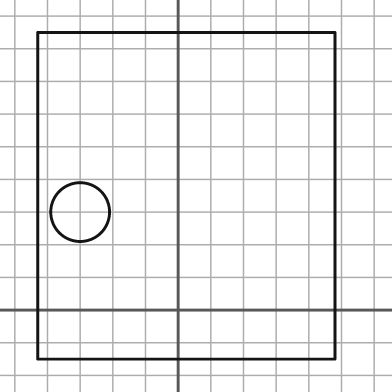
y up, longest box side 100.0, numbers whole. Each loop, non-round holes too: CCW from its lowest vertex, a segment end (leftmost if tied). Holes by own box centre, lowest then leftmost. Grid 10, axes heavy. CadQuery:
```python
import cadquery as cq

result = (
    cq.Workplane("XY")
    .moveTo(-43.0, -15.0)
    .lineTo(48.0, -15.0)
    .lineTo(48.0, 85.0)
    .lineTo(-43.0, 85.0)
    .close()
    .moveTo(-30.0, 30.0)
    .circle(9.0)
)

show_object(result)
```